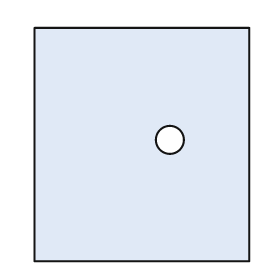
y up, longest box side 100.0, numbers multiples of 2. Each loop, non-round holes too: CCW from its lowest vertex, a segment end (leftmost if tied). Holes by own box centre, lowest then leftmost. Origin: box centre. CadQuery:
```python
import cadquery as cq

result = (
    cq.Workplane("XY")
    .moveTo(-46.0, -50.0)
    .lineTo(46.0, -50.0)
    .lineTo(46.0, 50.0)
    .lineTo(-46.0, 50.0)
    .close()
    .moveTo(12.0, 2.0)
    .circle(6.0)
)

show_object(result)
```